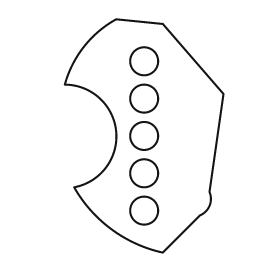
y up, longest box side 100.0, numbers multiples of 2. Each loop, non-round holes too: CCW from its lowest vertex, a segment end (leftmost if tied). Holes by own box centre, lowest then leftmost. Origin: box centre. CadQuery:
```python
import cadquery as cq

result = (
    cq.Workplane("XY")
    .moveTo(8.0, -50.0)
    .lineTo(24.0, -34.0)
    .threePointArc((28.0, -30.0), (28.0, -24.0))
    .lineTo(34.0, 18.0)
    .lineTo(8.0, 48.0)
    .lineTo(-12.0, 50.0)
    .threePointArc((-26.0, 38.0), (-34.0, 22.0))
    .threePointArc((-12.0, 2.0), (-30.0, -22.0))
    .threePointArc((-14.0, -40.0), (8.0, -50.0))
    .close()
    .moveTo(0.0, -32.0)
    .circle(6.0)
    .moveTo(0.0, -16.0)
    .circle(6.0)
    .moveTo(0.0, 0.0)
    .circle(6.0)
    .moveTo(0.0, 16.0)
    .circle(6.0)
    .moveTo(0.0, 32.0)
    .circle(6.0)
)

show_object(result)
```